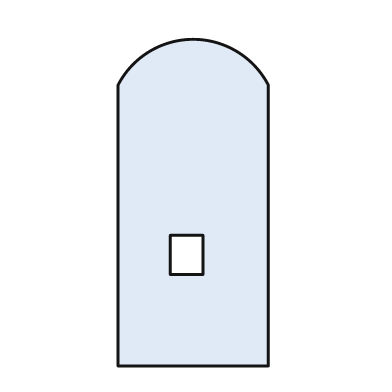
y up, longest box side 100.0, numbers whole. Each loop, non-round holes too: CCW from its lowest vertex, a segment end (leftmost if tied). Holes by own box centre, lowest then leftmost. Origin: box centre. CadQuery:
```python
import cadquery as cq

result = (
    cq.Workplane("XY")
    .moveTo(-23.0, -50.0)
    .lineTo(23.0, -50.0)
    .lineTo(23.0, 36.0)
    .threePointArc((0.0, 50.0), (-23.0, 36.0))
    .close()
    .moveTo(-7.0, -22.0)
    .lineTo(3.0, -22.0)
    .lineTo(3.0, -10.0)
    .lineTo(-7.0, -10.0)
    .close()
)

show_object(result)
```